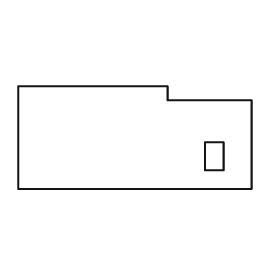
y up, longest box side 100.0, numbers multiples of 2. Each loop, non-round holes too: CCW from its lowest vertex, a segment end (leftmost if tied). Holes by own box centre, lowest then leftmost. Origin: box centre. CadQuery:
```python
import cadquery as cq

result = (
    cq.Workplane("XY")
    .moveTo(-50.0, -22.0)
    .lineTo(50.0, -22.0)
    .lineTo(50.0, 16.0)
    .lineTo(14.0, 16.0)
    .lineTo(14.0, 22.0)
    .lineTo(-50.0, 22.0)
    .close()
    .moveTo(30.0, -14.0)
    .lineTo(38.0, -14.0)
    .lineTo(38.0, -2.0)
    .lineTo(30.0, -2.0)
    .close()
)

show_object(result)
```